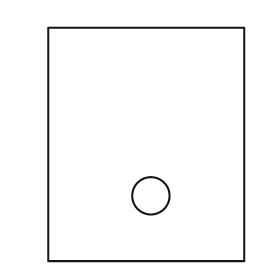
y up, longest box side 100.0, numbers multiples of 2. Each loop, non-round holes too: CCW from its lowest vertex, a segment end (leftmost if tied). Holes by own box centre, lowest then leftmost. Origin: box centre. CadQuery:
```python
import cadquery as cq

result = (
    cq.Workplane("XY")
    .moveTo(-42.0, -50.0)
    .lineTo(42.0, -50.0)
    .lineTo(42.0, 50.0)
    .lineTo(-42.0, 50.0)
    .close()
    .moveTo(2.0, -22.0)
    .circle(8.0)
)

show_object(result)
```